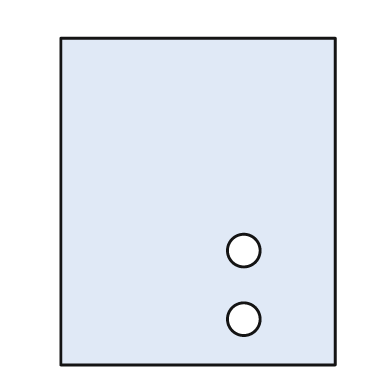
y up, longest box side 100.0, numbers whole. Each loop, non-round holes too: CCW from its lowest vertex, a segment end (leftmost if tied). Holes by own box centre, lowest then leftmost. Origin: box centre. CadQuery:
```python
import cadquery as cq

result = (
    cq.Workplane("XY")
    .moveTo(-42.0, -50.0)
    .lineTo(42.0, -50.0)
    .lineTo(42.0, 50.0)
    .lineTo(-42.0, 50.0)
    .close()
    .moveTo(14.0, -36.0)
    .circle(5.0)
    .moveTo(14.0, -15.0)
    .circle(5.0)
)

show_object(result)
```